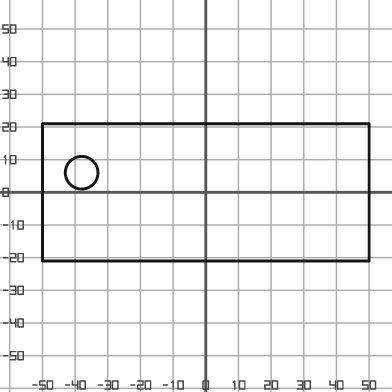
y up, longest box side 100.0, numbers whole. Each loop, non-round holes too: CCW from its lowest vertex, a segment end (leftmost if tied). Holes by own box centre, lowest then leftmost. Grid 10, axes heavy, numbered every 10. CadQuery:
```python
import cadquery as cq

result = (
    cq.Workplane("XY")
    .moveTo(-50.0, -21.0)
    .lineTo(50.0, -21.0)
    .lineTo(50.0, 21.0)
    .lineTo(-50.0, 21.0)
    .close()
    .moveTo(-38.0, 6.0)
    .circle(5.0)
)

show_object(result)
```